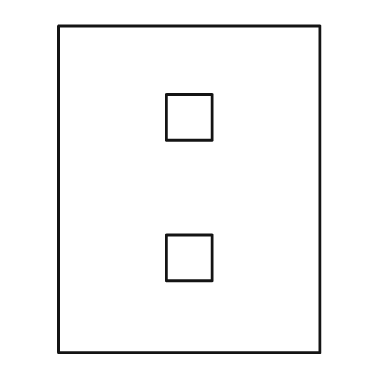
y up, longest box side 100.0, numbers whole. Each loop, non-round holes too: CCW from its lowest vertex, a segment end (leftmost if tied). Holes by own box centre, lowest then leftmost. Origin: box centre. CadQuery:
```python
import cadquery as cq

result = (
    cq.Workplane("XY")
    .moveTo(-40.0, -50.0)
    .lineTo(40.0, -50.0)
    .lineTo(40.0, 50.0)
    .lineTo(-40.0, 50.0)
    .close()
    .moveTo(-7.0, -28.0)
    .lineTo(7.0, -28.0)
    .lineTo(7.0, -14.0)
    .lineTo(-7.0, -14.0)
    .close()
    .moveTo(-7.0, 15.0)
    .lineTo(7.0, 15.0)
    .lineTo(7.0, 29.0)
    .lineTo(-7.0, 29.0)
    .close()
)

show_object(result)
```